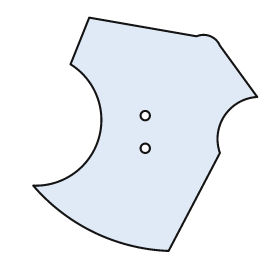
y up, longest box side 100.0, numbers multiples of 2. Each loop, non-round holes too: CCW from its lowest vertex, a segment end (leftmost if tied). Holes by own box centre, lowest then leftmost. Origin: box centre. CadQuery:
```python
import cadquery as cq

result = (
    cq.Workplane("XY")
    .moveTo(10.0, -50.0)
    .lineTo(32.0, -8.0)
    .threePointArc((34.0, 8.0), (48.0, 16.0))
    .lineTo(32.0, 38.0)
    .threePointArc((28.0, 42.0), (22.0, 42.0))
    .lineTo(-24.0, 50.0)
    .lineTo(-32.0, 30.0)
    .threePointArc((-20.0, -2.0), (-48.0, -22.0))
    .threePointArc((-22.0, -42.0), (10.0, -50.0))
    .close()
    .moveTo(0.0, -6.0)
    .circle(2.0)
    .moveTo(0.0, 8.0)
    .circle(2.0)
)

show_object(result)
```